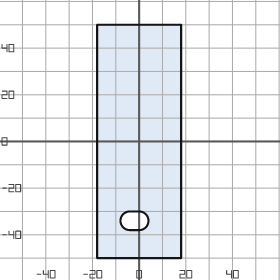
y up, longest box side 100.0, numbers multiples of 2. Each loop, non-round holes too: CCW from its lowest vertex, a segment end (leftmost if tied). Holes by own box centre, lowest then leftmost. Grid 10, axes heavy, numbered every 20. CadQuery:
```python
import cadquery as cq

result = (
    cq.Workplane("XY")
    .moveTo(-18.0, -50.0)
    .lineTo(18.0, -50.0)
    .lineTo(18.0, 50.0)
    .lineTo(-18.0, 50.0)
    .close()
    .moveTo(-4.0, -38.0)
    .lineTo(0.0, -38.0)
    .threePointArc((4.0, -34.0), (0.0, -30.0))
    .lineTo(-4.0, -30.0)
    .threePointArc((-8.0, -34.0), (-4.0, -38.0))
    .close()
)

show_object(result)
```